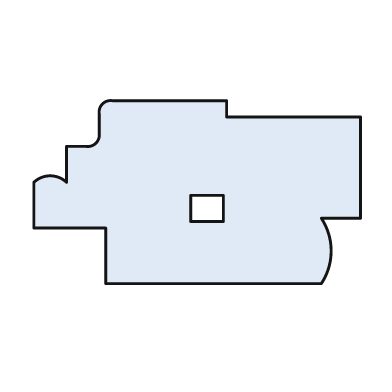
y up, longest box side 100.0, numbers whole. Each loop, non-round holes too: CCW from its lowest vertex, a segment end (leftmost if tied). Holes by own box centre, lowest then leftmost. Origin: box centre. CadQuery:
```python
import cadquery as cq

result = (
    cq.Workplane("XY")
    .moveTo(-28.0, -28.0)
    .lineTo(38.0, -28.0)
    .threePointArc((41.0, -18.0), (38.0, -8.0))
    .lineTo(50.0, -8.0)
    .lineTo(50.0, 23.0)
    .lineTo(9.0, 23.0)
    .lineTo(9.0, 28.0)
    .lineTo(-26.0, 28.0)
    .threePointArc((-29.0, 27.0), (-30.0, 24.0))
    .lineTo(-30.0, 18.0)
    .threePointArc((-31.0, 15.0), (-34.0, 14.0))
    .lineTo(-40.0, 14.0)
    .lineTo(-40.0, 3.0)
    .threePointArc((-45.0, 5.0), (-50.0, 3.0))
    .lineTo(-50.0, -11.0)
    .lineTo(-28.0, -11.0)
    .close()
    .moveTo(-2.0, -9.0)
    .lineTo(8.0, -9.0)
    .lineTo(8.0, -1.0)
    .lineTo(-2.0, -1.0)
    .close()
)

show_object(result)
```